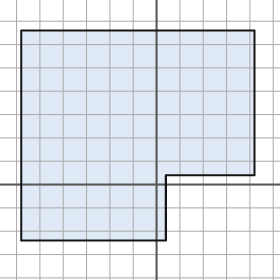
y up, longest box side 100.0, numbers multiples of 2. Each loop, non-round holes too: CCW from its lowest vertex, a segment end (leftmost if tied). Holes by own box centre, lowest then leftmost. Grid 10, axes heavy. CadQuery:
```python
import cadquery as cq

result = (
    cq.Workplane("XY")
    .moveTo(-58.0, -24.0)
    .lineTo(4.0, -24.0)
    .lineTo(4.0, 4.0)
    .lineTo(42.0, 4.0)
    .lineTo(42.0, 66.0)
    .lineTo(-58.0, 66.0)
    .close()
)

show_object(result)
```